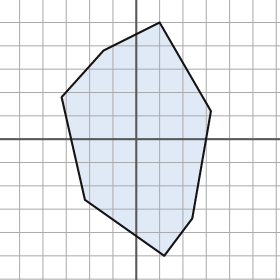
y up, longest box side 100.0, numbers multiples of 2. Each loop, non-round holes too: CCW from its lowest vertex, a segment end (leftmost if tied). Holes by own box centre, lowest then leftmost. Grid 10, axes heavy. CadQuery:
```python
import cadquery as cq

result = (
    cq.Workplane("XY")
    .moveTo(12.0, -50.0)
    .lineTo(24.0, -34.0)
    .lineTo(32.0, 12.0)
    .lineTo(10.0, 50.0)
    .lineTo(-14.0, 38.0)
    .lineTo(-32.0, 18.0)
    .lineTo(-22.0, -26.0)
    .close()
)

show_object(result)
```